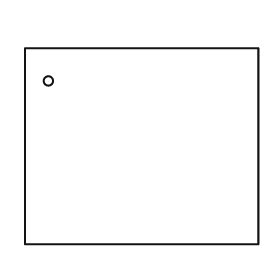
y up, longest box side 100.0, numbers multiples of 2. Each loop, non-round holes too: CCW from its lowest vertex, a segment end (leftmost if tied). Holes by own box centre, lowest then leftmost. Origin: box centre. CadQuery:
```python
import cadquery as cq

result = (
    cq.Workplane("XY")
    .moveTo(-50.0, -42.0)
    .lineTo(50.0, -42.0)
    .lineTo(50.0, 42.0)
    .lineTo(-50.0, 42.0)
    .close()
    .moveTo(-40.0, 28.0)
    .circle(2.0)
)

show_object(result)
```